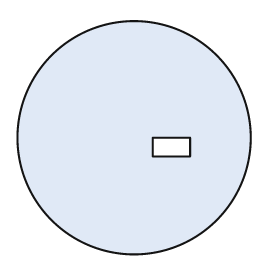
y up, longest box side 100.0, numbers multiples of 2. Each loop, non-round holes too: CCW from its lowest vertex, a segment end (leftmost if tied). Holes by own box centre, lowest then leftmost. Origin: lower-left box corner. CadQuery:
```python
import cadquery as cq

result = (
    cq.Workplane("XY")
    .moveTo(50.0, 50.0)
    .circle(50.0)
    .moveTo(58.0, 42.0)
    .lineTo(74.0, 42.0)
    .lineTo(74.0, 50.0)
    .lineTo(58.0, 50.0)
    .close()
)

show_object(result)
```